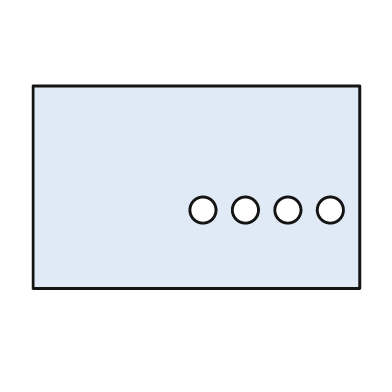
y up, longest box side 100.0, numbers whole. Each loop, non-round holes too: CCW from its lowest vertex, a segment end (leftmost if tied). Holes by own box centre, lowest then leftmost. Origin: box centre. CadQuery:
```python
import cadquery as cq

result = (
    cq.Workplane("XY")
    .moveTo(-50.0, -31.0)
    .lineTo(50.0, -31.0)
    .lineTo(50.0, 31.0)
    .lineTo(-50.0, 31.0)
    .close()
    .moveTo(2.0, -7.0)
    .circle(4.0)
    .moveTo(15.0, -7.0)
    .circle(4.0)
    .moveTo(28.0, -7.0)
    .circle(4.0)
    .moveTo(41.0, -7.0)
    .circle(4.0)
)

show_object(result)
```